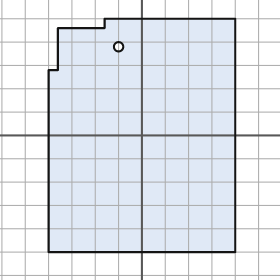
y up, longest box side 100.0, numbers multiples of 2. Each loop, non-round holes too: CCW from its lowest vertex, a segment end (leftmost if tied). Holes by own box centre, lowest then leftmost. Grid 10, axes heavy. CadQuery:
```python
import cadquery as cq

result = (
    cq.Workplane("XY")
    .moveTo(-40.0, -50.0)
    .lineTo(40.0, -50.0)
    .lineTo(40.0, 50.0)
    .lineTo(-16.0, 50.0)
    .lineTo(-16.0, 46.0)
    .lineTo(-36.0, 46.0)
    .lineTo(-36.0, 28.0)
    .lineTo(-40.0, 28.0)
    .close()
    .moveTo(-10.0, 38.0)
    .circle(2.0)
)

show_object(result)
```